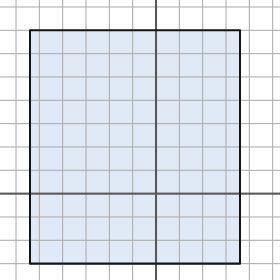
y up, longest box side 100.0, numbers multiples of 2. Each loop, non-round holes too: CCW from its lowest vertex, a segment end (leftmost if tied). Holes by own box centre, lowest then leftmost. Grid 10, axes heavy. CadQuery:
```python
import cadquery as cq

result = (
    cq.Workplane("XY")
    .moveTo(-54.0, -30.0)
    .lineTo(36.0, -30.0)
    .lineTo(36.0, 70.0)
    .lineTo(-54.0, 70.0)
    .close()
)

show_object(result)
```